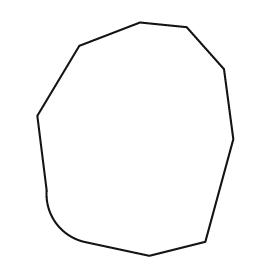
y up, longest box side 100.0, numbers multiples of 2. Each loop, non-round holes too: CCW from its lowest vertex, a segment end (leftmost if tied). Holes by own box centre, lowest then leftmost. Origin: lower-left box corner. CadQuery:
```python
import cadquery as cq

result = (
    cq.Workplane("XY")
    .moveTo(48.0, 0.0)
    .lineTo(72.0, 6.0)
    .lineTo(84.0, 50.0)
    .lineTo(80.0, 80.0)
    .lineTo(64.0, 98.0)
    .lineTo(44.0, 100.0)
    .lineTo(18.0, 90.0)
    .lineTo(0.0, 60.0)
    .lineTo(4.0, 28.0)
    .threePointArc((8.0, 14.0), (20.0, 6.0))
    .close()
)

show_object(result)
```